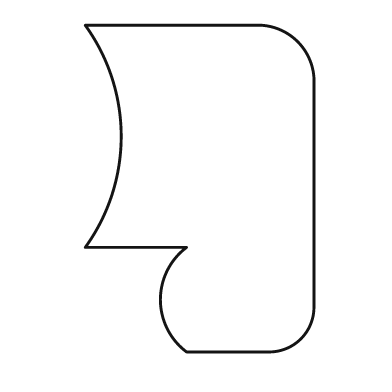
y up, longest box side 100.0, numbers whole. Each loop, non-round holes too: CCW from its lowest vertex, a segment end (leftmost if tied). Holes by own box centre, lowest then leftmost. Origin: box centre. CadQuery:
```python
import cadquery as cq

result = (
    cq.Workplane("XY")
    .moveTo(-4.0, -50.0)
    .lineTo(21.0, -50.0)
    .threePointArc((31.0, -46.0), (35.0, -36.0))
    .lineTo(35.0, 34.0)
    .threePointArc((30.0, 45.0), (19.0, 50.0))
    .lineTo(-35.0, 50.0)
    .threePointArc((-24.0, 16.0), (-35.0, -18.0))
    .lineTo(-4.0, -18.0)
    .threePointArc((-12.0, -34.0), (-4.0, -50.0))
    .close()
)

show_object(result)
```